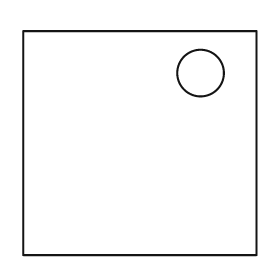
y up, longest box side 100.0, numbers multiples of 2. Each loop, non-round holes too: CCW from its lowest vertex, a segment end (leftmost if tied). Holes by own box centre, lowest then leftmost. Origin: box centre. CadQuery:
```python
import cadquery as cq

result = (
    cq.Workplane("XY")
    .moveTo(-50.0, -48.0)
    .lineTo(50.0, -48.0)
    .lineTo(50.0, 48.0)
    .lineTo(-50.0, 48.0)
    .close()
    .moveTo(26.0, 30.0)
    .circle(10.0)
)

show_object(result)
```